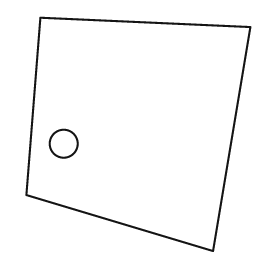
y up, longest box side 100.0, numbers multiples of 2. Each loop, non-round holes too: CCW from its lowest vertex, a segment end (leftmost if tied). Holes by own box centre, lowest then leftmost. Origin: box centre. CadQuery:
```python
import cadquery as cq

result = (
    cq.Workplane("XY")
    .moveTo(32.0, -50.0)
    .lineTo(48.0, 46.0)
    .lineTo(-42.0, 50.0)
    .lineTo(-48.0, -26.0)
    .close()
    .moveTo(-32.0, -4.0)
    .circle(6.0)
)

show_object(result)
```